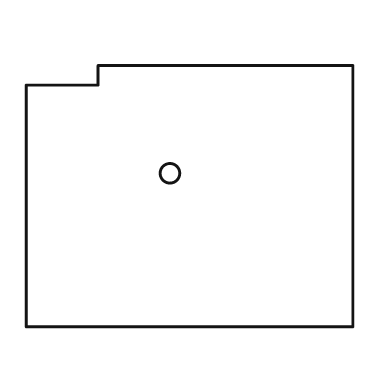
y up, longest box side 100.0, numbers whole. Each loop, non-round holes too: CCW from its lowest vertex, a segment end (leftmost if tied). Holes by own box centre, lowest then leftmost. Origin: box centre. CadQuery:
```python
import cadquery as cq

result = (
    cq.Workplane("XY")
    .moveTo(-50.0, -40.0)
    .lineTo(50.0, -40.0)
    .lineTo(50.0, 40.0)
    .lineTo(-28.0, 40.0)
    .lineTo(-28.0, 34.0)
    .lineTo(-50.0, 34.0)
    .close()
    .moveTo(-6.0, 7.0)
    .circle(3.0)
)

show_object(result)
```